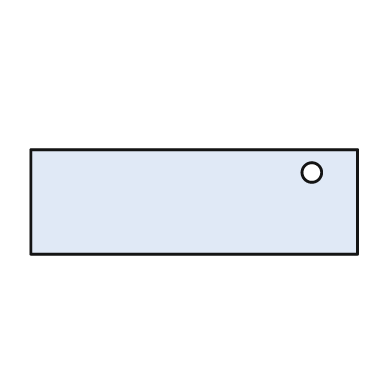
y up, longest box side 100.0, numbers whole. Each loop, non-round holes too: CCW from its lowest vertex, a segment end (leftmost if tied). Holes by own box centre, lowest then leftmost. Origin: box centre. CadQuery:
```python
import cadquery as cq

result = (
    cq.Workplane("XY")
    .moveTo(-50.0, -16.0)
    .lineTo(50.0, -16.0)
    .lineTo(50.0, 16.0)
    .lineTo(-50.0, 16.0)
    .close()
    .moveTo(36.0, 9.0)
    .circle(3.0)
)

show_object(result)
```